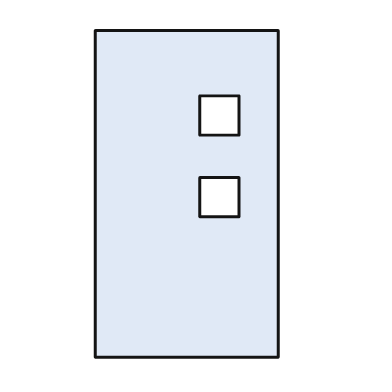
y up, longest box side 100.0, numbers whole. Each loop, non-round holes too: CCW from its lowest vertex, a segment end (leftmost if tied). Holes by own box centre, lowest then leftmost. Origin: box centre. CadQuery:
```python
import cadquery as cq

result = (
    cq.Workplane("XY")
    .moveTo(-28.0, -50.0)
    .lineTo(28.0, -50.0)
    .lineTo(28.0, 50.0)
    .lineTo(-28.0, 50.0)
    .close()
    .moveTo(4.0, -7.0)
    .lineTo(16.0, -7.0)
    .lineTo(16.0, 5.0)
    .lineTo(4.0, 5.0)
    .close()
    .moveTo(4.0, 18.0)
    .lineTo(16.0, 18.0)
    .lineTo(16.0, 30.0)
    .lineTo(4.0, 30.0)
    .close()
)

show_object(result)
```